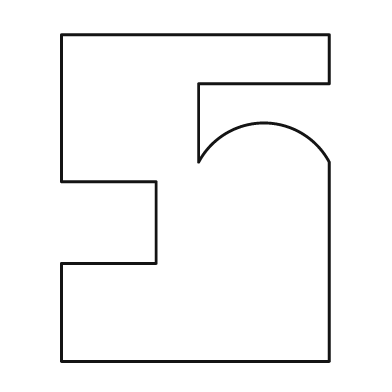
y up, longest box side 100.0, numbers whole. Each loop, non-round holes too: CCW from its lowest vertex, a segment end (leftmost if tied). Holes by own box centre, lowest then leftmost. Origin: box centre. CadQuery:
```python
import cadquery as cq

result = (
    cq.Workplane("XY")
    .moveTo(-41.0, -50.0)
    .lineTo(41.0, -50.0)
    .lineTo(41.0, 11.0)
    .threePointArc((21.0, 23.0), (1.0, 11.0))
    .lineTo(1.0, 35.0)
    .lineTo(41.0, 35.0)
    .lineTo(41.0, 50.0)
    .lineTo(-41.0, 50.0)
    .lineTo(-41.0, 5.0)
    .lineTo(-12.0, 5.0)
    .lineTo(-12.0, -20.0)
    .lineTo(-41.0, -20.0)
    .close()
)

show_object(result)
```